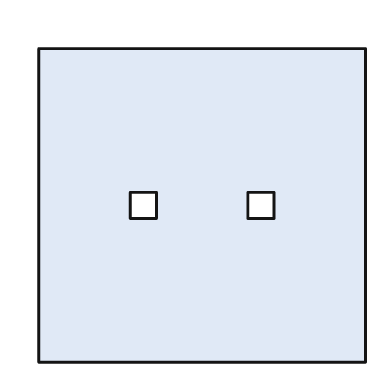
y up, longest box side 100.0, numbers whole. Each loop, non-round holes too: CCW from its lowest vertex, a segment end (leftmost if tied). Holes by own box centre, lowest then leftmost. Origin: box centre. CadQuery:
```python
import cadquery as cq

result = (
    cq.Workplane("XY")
    .moveTo(-50.0, -48.0)
    .lineTo(50.0, -48.0)
    .lineTo(50.0, 48.0)
    .lineTo(-50.0, 48.0)
    .close()
    .moveTo(-22.0, -4.0)
    .lineTo(-14.0, -4.0)
    .lineTo(-14.0, 4.0)
    .lineTo(-22.0, 4.0)
    .close()
    .moveTo(14.0, -4.0)
    .lineTo(22.0, -4.0)
    .lineTo(22.0, 4.0)
    .lineTo(14.0, 4.0)
    .close()
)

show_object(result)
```